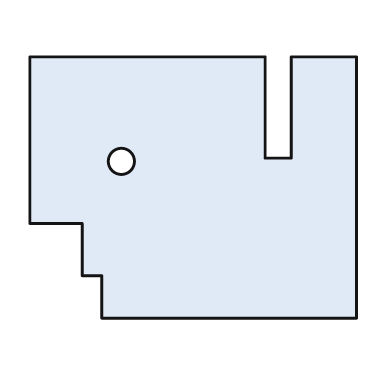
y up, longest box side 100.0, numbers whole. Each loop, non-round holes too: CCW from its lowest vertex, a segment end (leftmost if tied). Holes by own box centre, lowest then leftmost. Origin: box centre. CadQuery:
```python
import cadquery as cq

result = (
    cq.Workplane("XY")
    .moveTo(-28.0, -40.0)
    .lineTo(50.0, -40.0)
    .lineTo(50.0, 40.0)
    .lineTo(30.0, 40.0)
    .lineTo(30.0, 9.0)
    .lineTo(22.0, 9.0)
    .lineTo(22.0, 40.0)
    .lineTo(-50.0, 40.0)
    .lineTo(-50.0, -11.0)
    .lineTo(-34.0, -11.0)
    .lineTo(-34.0, -27.0)
    .lineTo(-28.0, -27.0)
    .close()
    .moveTo(-22.0, 8.0)
    .circle(4.0)
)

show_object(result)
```